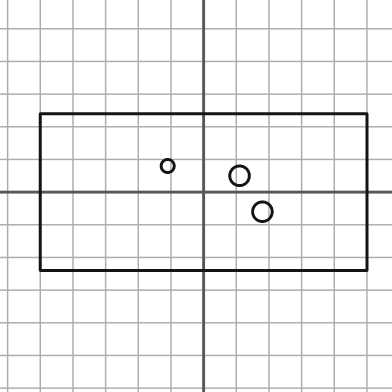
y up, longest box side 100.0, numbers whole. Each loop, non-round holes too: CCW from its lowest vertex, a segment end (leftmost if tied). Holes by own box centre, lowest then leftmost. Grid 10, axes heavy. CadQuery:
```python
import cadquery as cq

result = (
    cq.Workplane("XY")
    .moveTo(-50.0, -24.0)
    .lineTo(50.0, -24.0)
    .lineTo(50.0, 24.0)
    .lineTo(-50.0, 24.0)
    .close()
    .moveTo(18.0, -6.0)
    .circle(3.0)
    .moveTo(11.0, 5.0)
    .circle(3.0)
    .moveTo(-11.0, 8.0)
    .circle(2.0)
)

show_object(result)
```